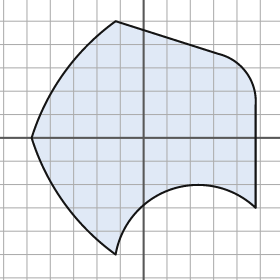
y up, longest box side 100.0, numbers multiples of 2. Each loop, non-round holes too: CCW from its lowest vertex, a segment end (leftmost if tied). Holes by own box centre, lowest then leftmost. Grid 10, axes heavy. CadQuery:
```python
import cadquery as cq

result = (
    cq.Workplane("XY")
    .moveTo(-12.0, -50.0)
    .threePointArc((12.0, -22.0), (48.0, -30.0))
    .lineTo(48.0, 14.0)
    .threePointArc((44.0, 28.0), (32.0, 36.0))
    .lineTo(-12.0, 50.0)
    .threePointArc((-34.0, 28.0), (-48.0, 0.0))
    .threePointArc((-34.0, -28.0), (-12.0, -50.0))
    .close()
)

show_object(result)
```